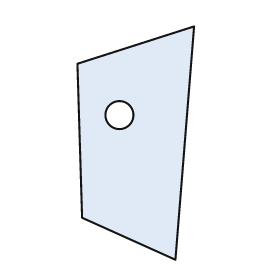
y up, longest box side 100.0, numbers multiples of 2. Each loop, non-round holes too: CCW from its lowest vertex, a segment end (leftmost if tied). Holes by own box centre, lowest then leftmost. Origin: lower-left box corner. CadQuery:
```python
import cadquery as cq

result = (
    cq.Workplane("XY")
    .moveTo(42.0, 0.0)
    .lineTo(50.0, 100.0)
    .lineTo(0.0, 84.0)
    .lineTo(2.0, 18.0)
    .close()
    .moveTo(18.0, 62.0)
    .circle(6.0)
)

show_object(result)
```